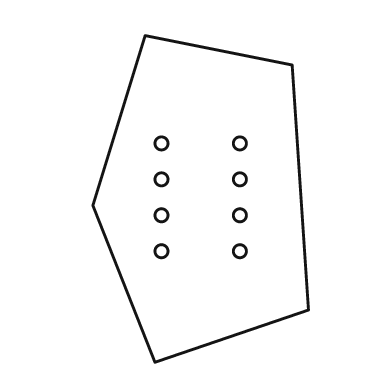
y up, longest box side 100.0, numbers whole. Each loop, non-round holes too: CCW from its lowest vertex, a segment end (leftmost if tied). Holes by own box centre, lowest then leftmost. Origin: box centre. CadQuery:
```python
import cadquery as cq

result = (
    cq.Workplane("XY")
    .moveTo(-14.0, -50.0)
    .lineTo(33.0, -34.0)
    .lineTo(28.0, 41.0)
    .lineTo(-17.0, 50.0)
    .lineTo(-33.0, -2.0)
    .close()
    .moveTo(-12.0, -16.0)
    .circle(2.0)
    .moveTo(12.0, -16.0)
    .circle(2.0)
    .moveTo(-12.0, -5.0)
    .circle(2.0)
    .moveTo(12.0, -5.0)
    .circle(2.0)
    .moveTo(-12.0, 6.0)
    .circle(2.0)
    .moveTo(12.0, 6.0)
    .circle(2.0)
    .moveTo(-12.0, 17.0)
    .circle(2.0)
    .moveTo(12.0, 17.0)
    .circle(2.0)
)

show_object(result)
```